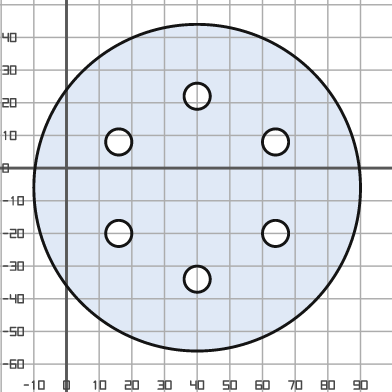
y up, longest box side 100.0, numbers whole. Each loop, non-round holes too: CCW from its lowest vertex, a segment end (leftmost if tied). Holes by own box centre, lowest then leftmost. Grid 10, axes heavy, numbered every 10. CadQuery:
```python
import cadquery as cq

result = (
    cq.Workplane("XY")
    .moveTo(40.0, -6.0)
    .circle(50.0)
    .moveTo(40.0, -34.0)
    .circle(4.0)
    .moveTo(16.0, -20.0)
    .circle(4.0)
    .moveTo(64.0, -20.0)
    .circle(4.0)
    .moveTo(16.0, 8.0)
    .circle(4.0)
    .moveTo(64.0, 8.0)
    .circle(4.0)
    .moveTo(40.0, 22.0)
    .circle(4.0)
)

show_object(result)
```